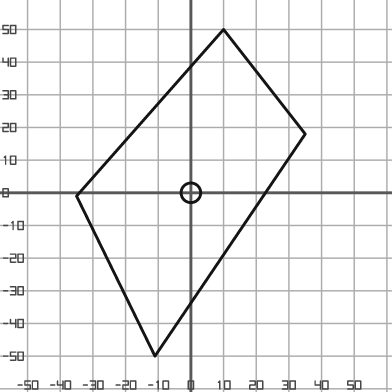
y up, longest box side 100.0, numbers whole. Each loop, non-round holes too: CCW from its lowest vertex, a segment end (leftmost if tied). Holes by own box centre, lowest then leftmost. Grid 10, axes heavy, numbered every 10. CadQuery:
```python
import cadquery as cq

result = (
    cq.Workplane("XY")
    .moveTo(-11.0, -50.0)
    .lineTo(35.0, 18.0)
    .lineTo(10.0, 50.0)
    .lineTo(-35.0, -1.0)
    .close()
    .moveTo(0.0, 0.0)
    .circle(3.0)
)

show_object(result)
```